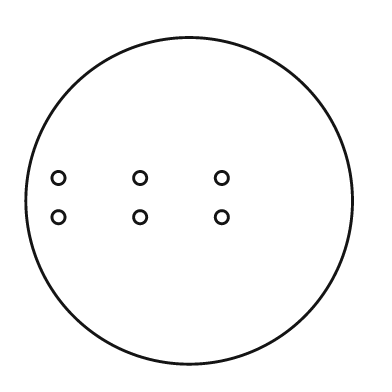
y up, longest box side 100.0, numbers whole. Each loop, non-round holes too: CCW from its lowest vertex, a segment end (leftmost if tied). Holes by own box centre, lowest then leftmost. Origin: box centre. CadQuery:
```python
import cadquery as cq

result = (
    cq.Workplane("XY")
    .moveTo(0.0, 0.0)
    .circle(50.0)
    .moveTo(-40.0, -5.0)
    .circle(2.0)
    .moveTo(-15.0, -5.0)
    .circle(2.0)
    .moveTo(10.0, -5.0)
    .circle(2.0)
    .moveTo(-40.0, 7.0)
    .circle(2.0)
    .moveTo(-15.0, 7.0)
    .circle(2.0)
    .moveTo(10.0, 7.0)
    .circle(2.0)
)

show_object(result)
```